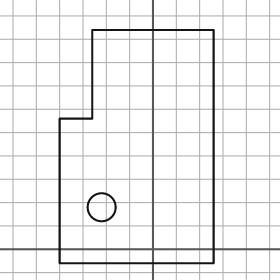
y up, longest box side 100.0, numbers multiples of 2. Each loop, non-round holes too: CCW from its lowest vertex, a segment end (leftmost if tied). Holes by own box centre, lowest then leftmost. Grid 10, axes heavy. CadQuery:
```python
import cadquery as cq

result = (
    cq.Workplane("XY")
    .moveTo(-40.0, -6.0)
    .lineTo(26.0, -6.0)
    .lineTo(26.0, 94.0)
    .lineTo(-26.0, 94.0)
    .lineTo(-26.0, 56.0)
    .lineTo(-40.0, 56.0)
    .close()
    .moveTo(-22.0, 18.0)
    .circle(6.0)
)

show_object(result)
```